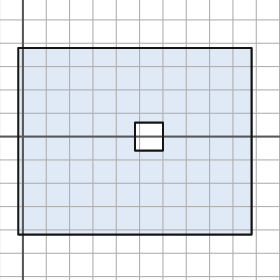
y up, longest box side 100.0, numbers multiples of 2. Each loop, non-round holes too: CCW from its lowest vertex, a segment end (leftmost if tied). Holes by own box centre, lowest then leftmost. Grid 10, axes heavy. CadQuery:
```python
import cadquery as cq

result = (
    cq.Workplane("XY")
    .moveTo(-2.0, -42.0)
    .lineTo(98.0, -42.0)
    .lineTo(98.0, 38.0)
    .lineTo(-2.0, 38.0)
    .close()
    .moveTo(48.0, -6.0)
    .lineTo(60.0, -6.0)
    .lineTo(60.0, 6.0)
    .lineTo(48.0, 6.0)
    .close()
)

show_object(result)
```